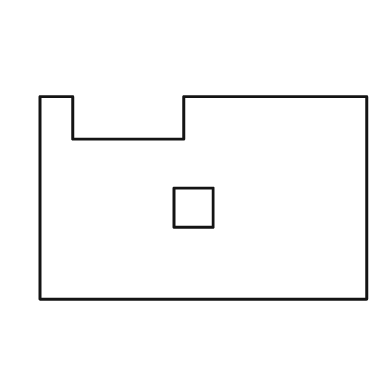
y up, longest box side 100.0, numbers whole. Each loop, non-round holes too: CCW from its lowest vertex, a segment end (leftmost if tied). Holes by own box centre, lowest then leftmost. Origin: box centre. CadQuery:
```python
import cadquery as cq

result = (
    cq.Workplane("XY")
    .moveTo(-50.0, -31.0)
    .lineTo(50.0, -31.0)
    .lineTo(50.0, 31.0)
    .lineTo(-6.0, 31.0)
    .lineTo(-6.0, 18.0)
    .lineTo(-40.0, 18.0)
    .lineTo(-40.0, 31.0)
    .lineTo(-50.0, 31.0)
    .close()
    .moveTo(-9.0, -9.0)
    .lineTo(3.0, -9.0)
    .lineTo(3.0, 3.0)
    .lineTo(-9.0, 3.0)
    .close()
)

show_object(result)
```